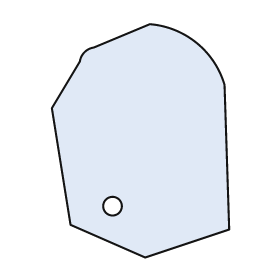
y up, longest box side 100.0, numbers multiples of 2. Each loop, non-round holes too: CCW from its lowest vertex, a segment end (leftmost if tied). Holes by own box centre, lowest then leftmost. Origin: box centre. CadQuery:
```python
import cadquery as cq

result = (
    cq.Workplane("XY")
    .moveTo(2.0, -50.0)
    .lineTo(38.0, -38.0)
    .lineTo(36.0, 24.0)
    .threePointArc((24.0, 42.0), (4.0, 50.0))
    .lineTo(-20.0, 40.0)
    .threePointArc((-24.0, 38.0), (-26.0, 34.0))
    .lineTo(-38.0, 14.0)
    .lineTo(-30.0, -36.0)
    .close()
    .moveTo(-12.0, -28.0)
    .circle(4.0)
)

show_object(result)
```